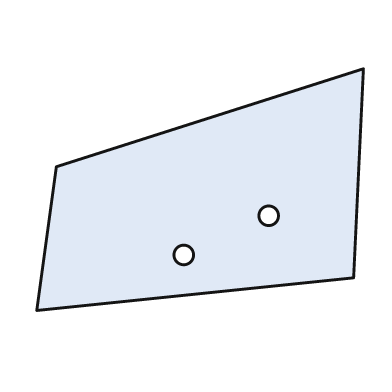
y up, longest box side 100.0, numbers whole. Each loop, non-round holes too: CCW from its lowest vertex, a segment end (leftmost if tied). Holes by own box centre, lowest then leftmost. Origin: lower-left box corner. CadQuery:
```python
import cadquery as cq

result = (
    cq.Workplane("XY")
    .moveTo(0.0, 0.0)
    .lineTo(97.0, 10.0)
    .lineTo(100.0, 74.0)
    .lineTo(6.0, 44.0)
    .close()
    .moveTo(45.0, 17.0)
    .circle(3.0)
    .moveTo(71.0, 29.0)
    .circle(3.0)
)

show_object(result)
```